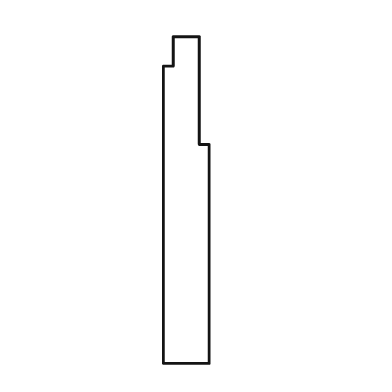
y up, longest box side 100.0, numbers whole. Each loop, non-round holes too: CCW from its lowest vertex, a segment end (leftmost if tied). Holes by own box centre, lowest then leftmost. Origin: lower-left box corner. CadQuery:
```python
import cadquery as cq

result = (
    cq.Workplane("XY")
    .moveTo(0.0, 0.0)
    .lineTo(14.0, 0.0)
    .lineTo(14.0, 67.0)
    .lineTo(11.0, 67.0)
    .lineTo(11.0, 100.0)
    .lineTo(3.0, 100.0)
    .lineTo(3.0, 91.0)
    .lineTo(0.0, 91.0)
    .close()
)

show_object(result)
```